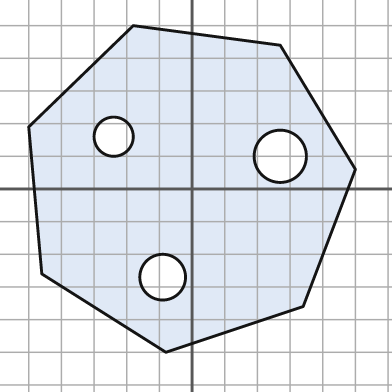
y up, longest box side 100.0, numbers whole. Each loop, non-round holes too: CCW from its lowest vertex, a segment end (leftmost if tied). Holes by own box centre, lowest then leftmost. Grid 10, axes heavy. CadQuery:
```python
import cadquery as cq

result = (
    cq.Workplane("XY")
    .moveTo(-8.0, -50.0)
    .lineTo(34.0, -36.0)
    .lineTo(50.0, 6.0)
    .lineTo(27.0, 44.0)
    .lineTo(-18.0, 50.0)
    .lineTo(-50.0, 19.0)
    .lineTo(-46.0, -26.0)
    .close()
    .moveTo(-9.0, -27.0)
    .circle(7.0)
    .moveTo(27.0, 10.0)
    .circle(8.0)
    .moveTo(-24.0, 16.0)
    .circle(6.0)
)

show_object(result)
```